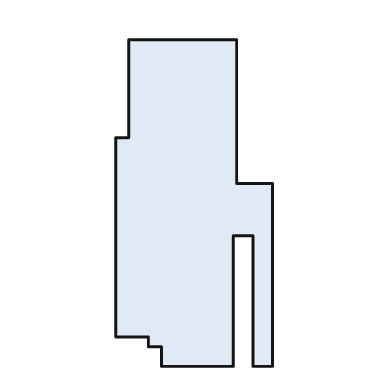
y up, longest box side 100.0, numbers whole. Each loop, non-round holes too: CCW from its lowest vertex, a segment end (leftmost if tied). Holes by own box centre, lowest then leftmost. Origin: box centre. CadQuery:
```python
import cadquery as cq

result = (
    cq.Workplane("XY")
    .moveTo(-10.0, -50.0)
    .lineTo(12.0, -50.0)
    .lineTo(12.0, -10.0)
    .lineTo(18.0, -10.0)
    .lineTo(18.0, -50.0)
    .lineTo(24.0, -50.0)
    .lineTo(24.0, 6.0)
    .lineTo(13.0, 6.0)
    .lineTo(13.0, 50.0)
    .lineTo(-20.0, 50.0)
    .lineTo(-20.0, 20.0)
    .lineTo(-24.0, 20.0)
    .lineTo(-24.0, -41.0)
    .lineTo(-14.0, -41.0)
    .lineTo(-14.0, -44.0)
    .lineTo(-10.0, -44.0)
    .close()
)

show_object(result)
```